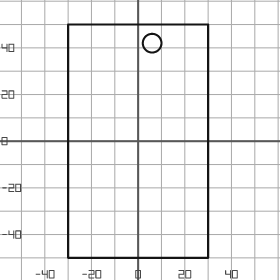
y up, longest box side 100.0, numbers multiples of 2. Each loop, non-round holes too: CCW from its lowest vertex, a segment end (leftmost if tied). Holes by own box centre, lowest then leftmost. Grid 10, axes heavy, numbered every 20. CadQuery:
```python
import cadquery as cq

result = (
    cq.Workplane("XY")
    .moveTo(-30.0, -50.0)
    .lineTo(30.0, -50.0)
    .lineTo(30.0, 50.0)
    .lineTo(-30.0, 50.0)
    .close()
    .moveTo(6.0, 42.0)
    .circle(4.0)
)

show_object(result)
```